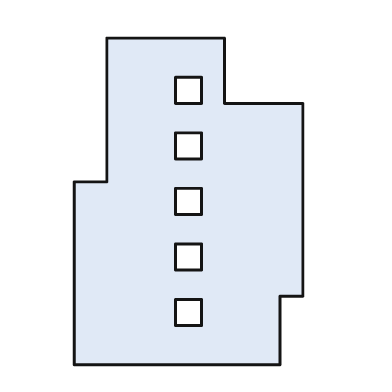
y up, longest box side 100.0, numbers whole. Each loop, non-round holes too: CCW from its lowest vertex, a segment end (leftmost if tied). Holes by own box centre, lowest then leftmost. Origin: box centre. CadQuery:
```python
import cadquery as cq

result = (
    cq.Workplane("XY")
    .moveTo(-35.0, -50.0)
    .lineTo(28.0, -50.0)
    .lineTo(28.0, -29.0)
    .lineTo(35.0, -29.0)
    .lineTo(35.0, 30.0)
    .lineTo(11.0, 30.0)
    .lineTo(11.0, 50.0)
    .lineTo(-25.0, 50.0)
    .lineTo(-25.0, 6.0)
    .lineTo(-35.0, 6.0)
    .close()
    .moveTo(-4.0, -38.0)
    .lineTo(4.0, -38.0)
    .lineTo(4.0, -30.0)
    .lineTo(-4.0, -30.0)
    .close()
    .moveTo(-4.0, -21.0)
    .lineTo(4.0, -21.0)
    .lineTo(4.0, -13.0)
    .lineTo(-4.0, -13.0)
    .close()
    .moveTo(-4.0, -4.0)
    .lineTo(4.0, -4.0)
    .lineTo(4.0, 4.0)
    .lineTo(-4.0, 4.0)
    .close()
    .moveTo(-4.0, 13.0)
    .lineTo(4.0, 13.0)
    .lineTo(4.0, 21.0)
    .lineTo(-4.0, 21.0)
    .close()
    .moveTo(-4.0, 30.0)
    .lineTo(4.0, 30.0)
    .lineTo(4.0, 38.0)
    .lineTo(-4.0, 38.0)
    .close()
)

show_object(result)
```